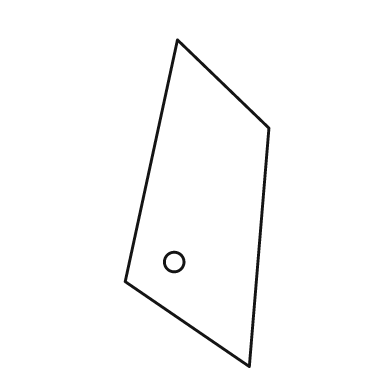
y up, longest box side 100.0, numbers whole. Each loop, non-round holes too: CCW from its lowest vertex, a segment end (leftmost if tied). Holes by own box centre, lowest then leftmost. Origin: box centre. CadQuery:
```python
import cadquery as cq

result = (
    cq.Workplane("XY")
    .moveTo(16.0, -50.0)
    .lineTo(22.0, 23.0)
    .lineTo(-6.0, 50.0)
    .lineTo(-22.0, -24.0)
    .close()
    .moveTo(-7.0, -18.0)
    .circle(3.0)
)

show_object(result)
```